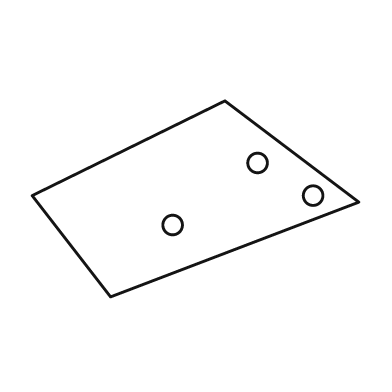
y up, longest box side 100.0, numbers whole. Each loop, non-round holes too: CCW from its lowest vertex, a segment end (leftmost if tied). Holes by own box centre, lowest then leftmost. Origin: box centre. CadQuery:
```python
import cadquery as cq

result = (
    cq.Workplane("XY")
    .moveTo(-26.0, -30.0)
    .lineTo(50.0, -1.0)
    .lineTo(9.0, 30.0)
    .lineTo(-50.0, 1.0)
    .close()
    .moveTo(-7.0, -8.0)
    .circle(3.0)
    .moveTo(36.0, 1.0)
    .circle(3.0)
    .moveTo(19.0, 11.0)
    .circle(3.0)
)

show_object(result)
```